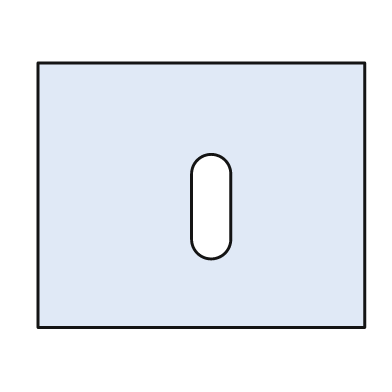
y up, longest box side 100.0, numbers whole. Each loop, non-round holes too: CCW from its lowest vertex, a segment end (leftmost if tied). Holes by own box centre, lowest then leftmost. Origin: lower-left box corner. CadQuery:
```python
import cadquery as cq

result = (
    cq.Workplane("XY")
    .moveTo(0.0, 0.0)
    .lineTo(100.0, 0.0)
    .lineTo(100.0, 81.0)
    .lineTo(0.0, 81.0)
    .close()
    .moveTo(47.0, 27.0)
    .threePointArc((53.0, 21.0), (59.0, 27.0))
    .lineTo(59.0, 47.0)
    .threePointArc((53.0, 53.0), (47.0, 47.0))
    .close()
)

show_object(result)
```